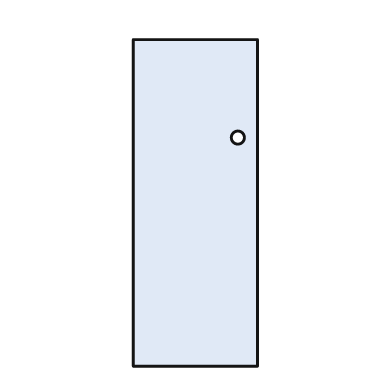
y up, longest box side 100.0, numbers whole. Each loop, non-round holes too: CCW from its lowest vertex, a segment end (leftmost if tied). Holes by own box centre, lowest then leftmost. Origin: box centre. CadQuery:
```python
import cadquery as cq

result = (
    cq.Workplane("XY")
    .moveTo(-19.0, -50.0)
    .lineTo(19.0, -50.0)
    .lineTo(19.0, 50.0)
    .lineTo(-19.0, 50.0)
    .close()
    .moveTo(13.0, 20.0)
    .circle(2.0)
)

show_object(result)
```